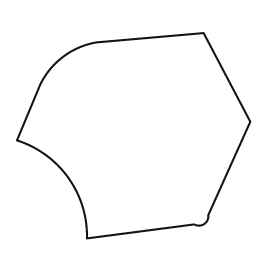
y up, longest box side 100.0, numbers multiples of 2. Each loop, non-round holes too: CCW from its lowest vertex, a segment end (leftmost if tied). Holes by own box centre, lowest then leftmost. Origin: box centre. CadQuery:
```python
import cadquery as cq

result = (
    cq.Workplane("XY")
    .moveTo(-20.0, -44.0)
    .lineTo(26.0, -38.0)
    .threePointArc((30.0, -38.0), (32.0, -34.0))
    .lineTo(50.0, 6.0)
    .lineTo(30.0, 44.0)
    .lineTo(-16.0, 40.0)
    .threePointArc((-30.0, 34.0), (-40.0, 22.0))
    .lineTo(-50.0, -2.0)
    .threePointArc((-28.0, -18.0), (-20.0, -44.0))
    .close()
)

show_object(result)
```